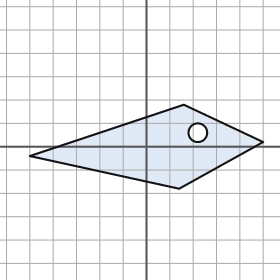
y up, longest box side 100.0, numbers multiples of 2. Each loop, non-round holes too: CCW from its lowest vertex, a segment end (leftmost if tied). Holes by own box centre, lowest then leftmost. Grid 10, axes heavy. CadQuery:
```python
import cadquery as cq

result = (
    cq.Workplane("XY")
    .moveTo(14.0, -18.0)
    .lineTo(50.0, 2.0)
    .lineTo(16.0, 18.0)
    .lineTo(-50.0, -4.0)
    .close()
    .moveTo(22.0, 6.0)
    .circle(4.0)
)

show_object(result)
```